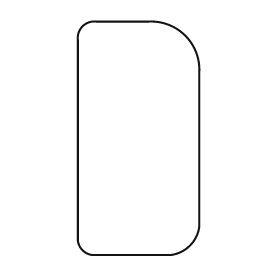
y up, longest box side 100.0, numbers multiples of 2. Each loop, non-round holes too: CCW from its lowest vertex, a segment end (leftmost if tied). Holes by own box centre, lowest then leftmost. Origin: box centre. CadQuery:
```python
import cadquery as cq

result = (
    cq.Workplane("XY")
    .moveTo(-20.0, -50.0)
    .lineTo(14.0, -50.0)
    .threePointArc((22.0, -46.0), (26.0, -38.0))
    .lineTo(26.0, 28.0)
    .threePointArc((20.0, 44.0), (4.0, 50.0))
    .lineTo(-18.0, 50.0)
    .threePointArc((-24.0, 48.0), (-26.0, 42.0))
    .lineTo(-26.0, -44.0)
    .threePointArc((-24.0, -48.0), (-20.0, -50.0))
    .close()
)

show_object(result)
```